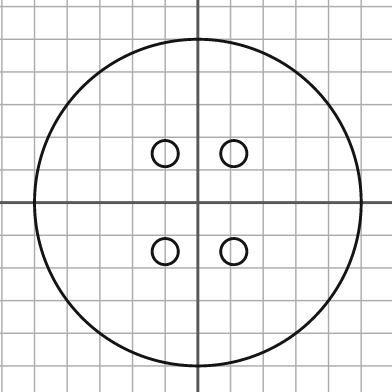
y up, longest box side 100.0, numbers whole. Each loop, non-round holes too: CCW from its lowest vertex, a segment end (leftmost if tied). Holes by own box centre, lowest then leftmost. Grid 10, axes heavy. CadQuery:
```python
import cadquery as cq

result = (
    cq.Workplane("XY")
    .moveTo(0.0, 0.0)
    .circle(50.0)
    .moveTo(-10.0, -15.0)
    .circle(4.0)
    .moveTo(11.0, -15.0)
    .circle(4.0)
    .moveTo(-10.0, 15.0)
    .circle(4.0)
    .moveTo(11.0, 15.0)
    .circle(4.0)
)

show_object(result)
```